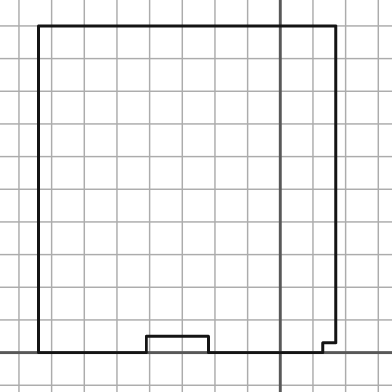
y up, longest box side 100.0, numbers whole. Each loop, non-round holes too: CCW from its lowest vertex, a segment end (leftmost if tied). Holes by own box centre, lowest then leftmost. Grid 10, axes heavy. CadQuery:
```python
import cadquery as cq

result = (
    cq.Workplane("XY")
    .moveTo(-74.0, 0.0)
    .lineTo(-41.0, 0.0)
    .lineTo(-41.0, 5.0)
    .lineTo(-22.0, 5.0)
    .lineTo(-22.0, 0.0)
    .lineTo(13.0, 0.0)
    .lineTo(13.0, 3.0)
    .lineTo(17.0, 3.0)
    .lineTo(17.0, 100.0)
    .lineTo(-74.0, 100.0)
    .close()
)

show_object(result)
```